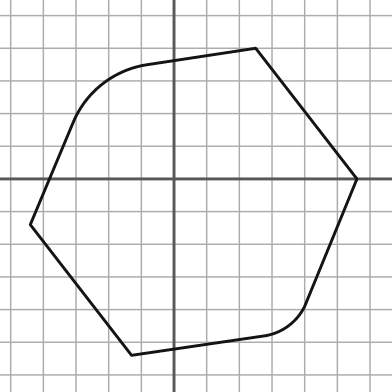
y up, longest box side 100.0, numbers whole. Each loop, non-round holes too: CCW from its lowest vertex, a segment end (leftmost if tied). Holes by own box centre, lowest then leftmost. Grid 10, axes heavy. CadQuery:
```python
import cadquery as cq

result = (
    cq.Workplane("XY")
    .moveTo(-13.0, -54.0)
    .lineTo(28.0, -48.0)
    .threePointArc((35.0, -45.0), (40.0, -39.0))
    .lineTo(56.0, 0.0)
    .lineTo(25.0, 40.0)
    .lineTo(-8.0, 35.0)
    .threePointArc((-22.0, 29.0), (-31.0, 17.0))
    .lineTo(-44.0, -14.0)
    .close()
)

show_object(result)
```